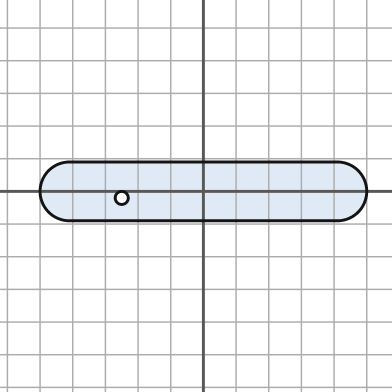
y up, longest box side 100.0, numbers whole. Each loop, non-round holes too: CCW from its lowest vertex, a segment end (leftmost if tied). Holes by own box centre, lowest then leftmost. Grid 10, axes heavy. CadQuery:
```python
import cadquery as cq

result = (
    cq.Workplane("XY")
    .moveTo(-41.0, -9.0)
    .lineTo(41.0, -9.0)
    .threePointArc((50.0, 0.0), (41.0, 9.0))
    .lineTo(-41.0, 9.0)
    .threePointArc((-50.0, 0.0), (-41.0, -9.0))
    .close()
    .moveTo(-25.0, -2.0)
    .circle(2.0)
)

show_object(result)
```